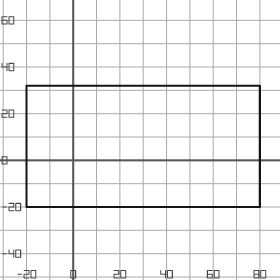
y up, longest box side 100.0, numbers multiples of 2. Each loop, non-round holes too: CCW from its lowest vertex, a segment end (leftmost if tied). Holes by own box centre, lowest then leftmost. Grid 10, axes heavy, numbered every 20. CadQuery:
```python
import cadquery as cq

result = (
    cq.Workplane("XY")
    .moveTo(-20.0, -20.0)
    .lineTo(80.0, -20.0)
    .lineTo(80.0, 32.0)
    .lineTo(-20.0, 32.0)
    .close()
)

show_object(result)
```